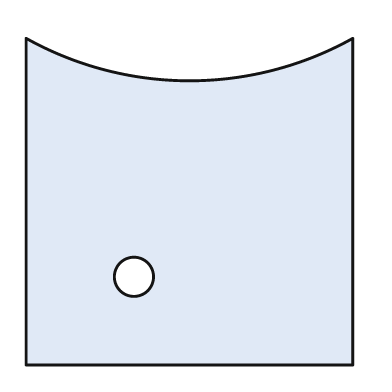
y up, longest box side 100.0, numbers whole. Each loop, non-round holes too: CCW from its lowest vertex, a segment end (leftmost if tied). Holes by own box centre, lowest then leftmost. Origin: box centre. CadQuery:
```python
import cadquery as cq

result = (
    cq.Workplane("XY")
    .moveTo(-50.0, -50.0)
    .lineTo(50.0, -50.0)
    .lineTo(50.0, 50.0)
    .threePointArc((0.0, 37.0), (-50.0, 50.0))
    .close()
    .moveTo(-17.0, -23.0)
    .circle(6.0)
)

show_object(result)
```